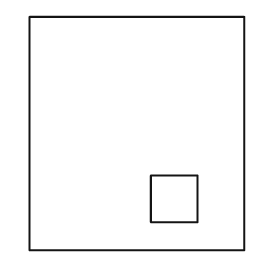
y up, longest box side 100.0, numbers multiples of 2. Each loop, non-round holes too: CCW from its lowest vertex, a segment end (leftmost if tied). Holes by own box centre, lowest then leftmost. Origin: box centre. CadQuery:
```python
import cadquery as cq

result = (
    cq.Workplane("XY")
    .moveTo(-46.0, -50.0)
    .lineTo(46.0, -50.0)
    .lineTo(46.0, 50.0)
    .lineTo(-46.0, 50.0)
    .close()
    .moveTo(6.0, -38.0)
    .lineTo(26.0, -38.0)
    .lineTo(26.0, -18.0)
    .lineTo(6.0, -18.0)
    .close()
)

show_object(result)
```